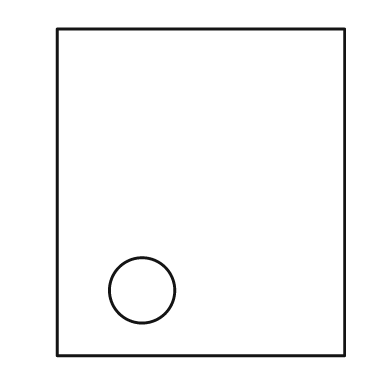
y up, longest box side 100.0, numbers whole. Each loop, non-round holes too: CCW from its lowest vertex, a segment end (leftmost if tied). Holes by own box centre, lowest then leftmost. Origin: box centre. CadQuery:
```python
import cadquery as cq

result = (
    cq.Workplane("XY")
    .moveTo(-44.0, -50.0)
    .lineTo(44.0, -50.0)
    .lineTo(44.0, 50.0)
    .lineTo(-44.0, 50.0)
    .close()
    .moveTo(-18.0, -30.0)
    .circle(10.0)
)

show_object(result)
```